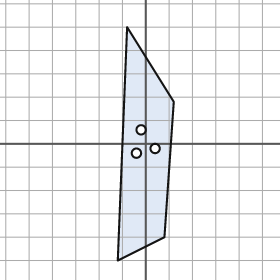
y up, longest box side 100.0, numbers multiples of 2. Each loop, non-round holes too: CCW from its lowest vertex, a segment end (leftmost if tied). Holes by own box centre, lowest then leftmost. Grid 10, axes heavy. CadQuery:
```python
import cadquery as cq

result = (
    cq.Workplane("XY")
    .moveTo(-12.0, -50.0)
    .lineTo(8.0, -40.0)
    .lineTo(12.0, 18.0)
    .lineTo(-8.0, 50.0)
    .close()
    .moveTo(-4.0, -4.0)
    .circle(2.0)
    .moveTo(4.0, -2.0)
    .circle(2.0)
    .moveTo(-2.0, 6.0)
    .circle(2.0)
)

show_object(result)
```